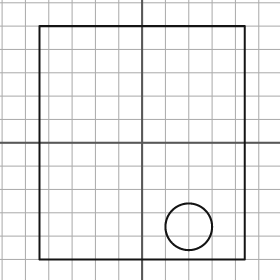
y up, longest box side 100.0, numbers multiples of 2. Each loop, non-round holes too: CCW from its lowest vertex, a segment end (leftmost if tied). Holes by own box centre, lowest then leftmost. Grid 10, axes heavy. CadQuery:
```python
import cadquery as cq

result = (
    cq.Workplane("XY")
    .moveTo(-44.0, -50.0)
    .lineTo(44.0, -50.0)
    .lineTo(44.0, 50.0)
    .lineTo(-44.0, 50.0)
    .close()
    .moveTo(20.0, -36.0)
    .circle(10.0)
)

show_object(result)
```